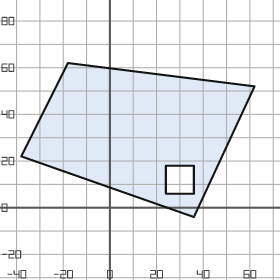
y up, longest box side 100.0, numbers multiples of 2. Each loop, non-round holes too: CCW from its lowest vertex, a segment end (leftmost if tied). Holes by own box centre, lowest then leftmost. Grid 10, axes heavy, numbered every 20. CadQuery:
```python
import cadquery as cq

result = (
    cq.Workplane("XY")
    .moveTo(36.0, -4.0)
    .lineTo(62.0, 52.0)
    .lineTo(-18.0, 62.0)
    .lineTo(-38.0, 22.0)
    .close()
    .moveTo(24.0, 6.0)
    .lineTo(36.0, 6.0)
    .lineTo(36.0, 18.0)
    .lineTo(24.0, 18.0)
    .close()
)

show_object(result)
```